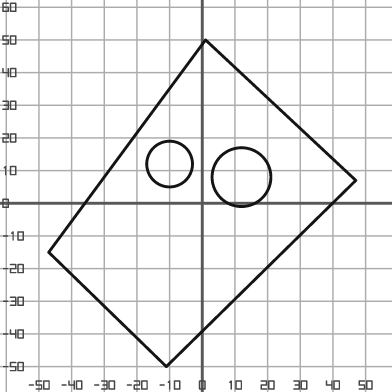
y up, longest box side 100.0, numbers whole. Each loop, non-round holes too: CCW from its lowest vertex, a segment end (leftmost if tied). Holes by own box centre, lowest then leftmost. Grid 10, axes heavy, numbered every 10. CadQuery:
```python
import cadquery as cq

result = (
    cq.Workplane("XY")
    .moveTo(-11.0, -50.0)
    .lineTo(47.0, 7.0)
    .lineTo(1.0, 50.0)
    .lineTo(-47.0, -15.0)
    .close()
    .moveTo(12.0, 8.0)
    .circle(9.0)
    .moveTo(-10.0, 12.0)
    .circle(7.0)
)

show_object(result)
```